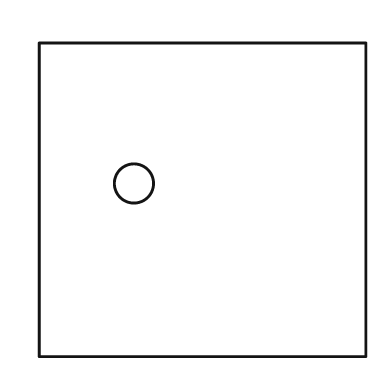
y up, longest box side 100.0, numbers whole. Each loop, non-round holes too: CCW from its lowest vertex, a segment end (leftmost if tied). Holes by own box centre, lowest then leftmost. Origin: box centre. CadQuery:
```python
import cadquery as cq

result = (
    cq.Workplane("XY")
    .moveTo(-50.0, -48.0)
    .lineTo(50.0, -48.0)
    .lineTo(50.0, 48.0)
    .lineTo(-50.0, 48.0)
    .close()
    .moveTo(-21.0, 5.0)
    .circle(6.0)
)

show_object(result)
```